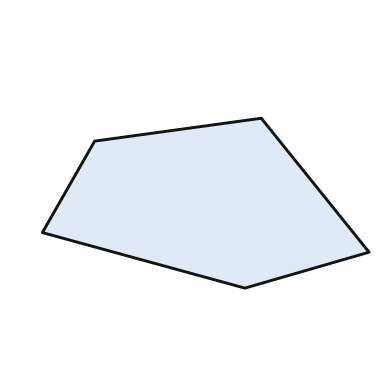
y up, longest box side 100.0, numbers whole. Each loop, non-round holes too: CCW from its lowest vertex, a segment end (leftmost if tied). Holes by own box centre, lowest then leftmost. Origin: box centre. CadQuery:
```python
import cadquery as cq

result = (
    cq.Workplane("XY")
    .moveTo(12.0, -26.0)
    .lineTo(50.0, -15.0)
    .lineTo(17.0, 26.0)
    .lineTo(-34.0, 19.0)
    .lineTo(-50.0, -9.0)
    .close()
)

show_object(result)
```